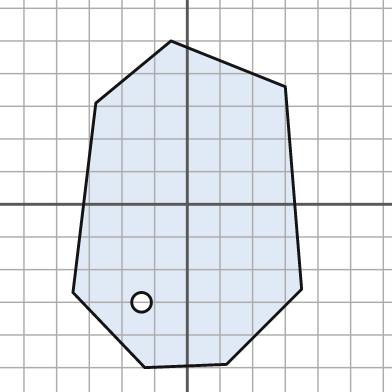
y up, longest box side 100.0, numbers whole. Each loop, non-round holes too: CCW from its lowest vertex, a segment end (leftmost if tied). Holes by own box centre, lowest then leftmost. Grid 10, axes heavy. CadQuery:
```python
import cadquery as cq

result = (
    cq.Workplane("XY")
    .moveTo(-13.0, -50.0)
    .lineTo(12.0, -49.0)
    .lineTo(35.0, -26.0)
    .lineTo(30.0, 36.0)
    .lineTo(-5.0, 50.0)
    .lineTo(-28.0, 31.0)
    .lineTo(-35.0, -27.0)
    .close()
    .moveTo(-14.0, -30.0)
    .circle(3.0)
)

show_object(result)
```